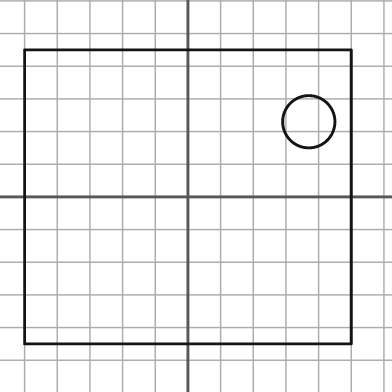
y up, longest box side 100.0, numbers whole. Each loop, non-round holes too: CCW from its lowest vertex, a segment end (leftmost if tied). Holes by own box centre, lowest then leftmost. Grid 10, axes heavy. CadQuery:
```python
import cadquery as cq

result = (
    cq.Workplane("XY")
    .moveTo(-50.0, -45.0)
    .lineTo(50.0, -45.0)
    .lineTo(50.0, 45.0)
    .lineTo(-50.0, 45.0)
    .close()
    .moveTo(37.0, 23.0)
    .circle(8.0)
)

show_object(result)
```